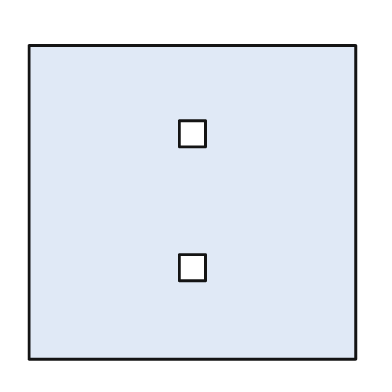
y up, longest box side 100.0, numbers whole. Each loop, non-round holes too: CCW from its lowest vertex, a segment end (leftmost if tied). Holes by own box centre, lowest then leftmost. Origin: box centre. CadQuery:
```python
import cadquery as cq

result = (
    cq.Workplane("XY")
    .moveTo(-50.0, -48.0)
    .lineTo(50.0, -48.0)
    .lineTo(50.0, 48.0)
    .lineTo(-50.0, 48.0)
    .close()
    .moveTo(-4.0, -24.0)
    .lineTo(4.0, -24.0)
    .lineTo(4.0, -16.0)
    .lineTo(-4.0, -16.0)
    .close()
    .moveTo(-4.0, 17.0)
    .lineTo(4.0, 17.0)
    .lineTo(4.0, 25.0)
    .lineTo(-4.0, 25.0)
    .close()
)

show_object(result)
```